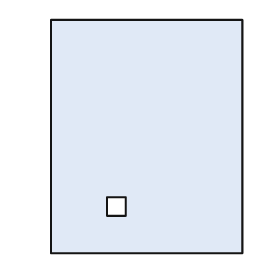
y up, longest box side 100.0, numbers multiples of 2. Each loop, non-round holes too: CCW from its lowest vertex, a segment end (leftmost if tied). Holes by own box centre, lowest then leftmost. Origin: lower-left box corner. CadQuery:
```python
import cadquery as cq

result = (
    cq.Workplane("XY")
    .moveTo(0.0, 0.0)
    .lineTo(82.0, 0.0)
    .lineTo(82.0, 100.0)
    .lineTo(0.0, 100.0)
    .close()
    .moveTo(24.0, 16.0)
    .lineTo(32.0, 16.0)
    .lineTo(32.0, 24.0)
    .lineTo(24.0, 24.0)
    .close()
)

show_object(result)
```